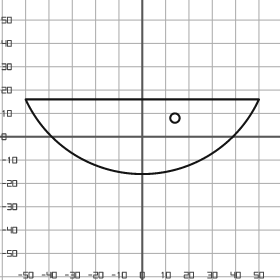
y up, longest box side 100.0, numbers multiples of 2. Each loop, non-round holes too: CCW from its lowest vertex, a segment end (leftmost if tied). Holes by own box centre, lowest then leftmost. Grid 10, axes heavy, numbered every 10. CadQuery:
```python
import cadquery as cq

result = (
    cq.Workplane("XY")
    .moveTo(-50.0, 16.0)
    .threePointArc((0.0, -16.0), (50.0, 16.0))
    .close()
    .moveTo(14.0, 8.0)
    .circle(2.0)
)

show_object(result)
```